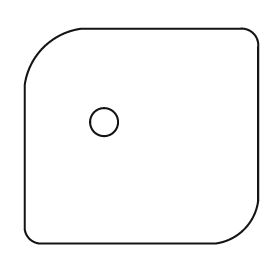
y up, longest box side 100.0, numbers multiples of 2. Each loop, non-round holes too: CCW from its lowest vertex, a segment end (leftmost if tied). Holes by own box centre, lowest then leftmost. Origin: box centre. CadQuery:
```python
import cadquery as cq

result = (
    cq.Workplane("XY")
    .moveTo(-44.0, -46.0)
    .lineTo(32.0, -46.0)
    .threePointArc((44.0, -40.0), (50.0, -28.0))
    .lineTo(50.0, 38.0)
    .threePointArc((48.0, 44.0), (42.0, 46.0))
    .lineTo(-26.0, 46.0)
    .threePointArc((-42.0, 38.0), (-50.0, 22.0))
    .lineTo(-50.0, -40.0)
    .threePointArc((-48.0, -44.0), (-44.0, -46.0))
    .close()
    .moveTo(-16.0, 6.0)
    .circle(6.0)
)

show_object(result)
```